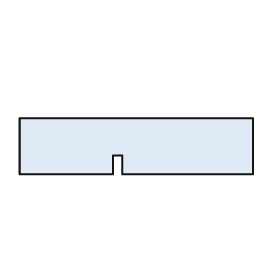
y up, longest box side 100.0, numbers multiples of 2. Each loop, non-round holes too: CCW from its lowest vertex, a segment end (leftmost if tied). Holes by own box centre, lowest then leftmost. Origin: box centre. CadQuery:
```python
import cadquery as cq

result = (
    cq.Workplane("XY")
    .moveTo(-50.0, -12.0)
    .lineTo(-10.0, -12.0)
    .lineTo(-10.0, -4.0)
    .lineTo(-6.0, -4.0)
    .lineTo(-6.0, -12.0)
    .lineTo(50.0, -12.0)
    .lineTo(50.0, 12.0)
    .lineTo(-50.0, 12.0)
    .close()
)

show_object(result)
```